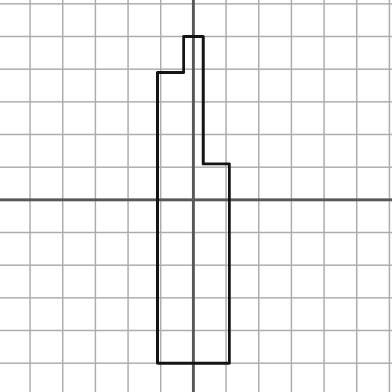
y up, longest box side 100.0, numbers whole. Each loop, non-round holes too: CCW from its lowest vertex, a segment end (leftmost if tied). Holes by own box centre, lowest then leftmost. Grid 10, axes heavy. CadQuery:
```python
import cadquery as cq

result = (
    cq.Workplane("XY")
    .moveTo(-11.0, -50.0)
    .lineTo(11.0, -50.0)
    .lineTo(11.0, 11.0)
    .lineTo(3.0, 11.0)
    .lineTo(3.0, 50.0)
    .lineTo(-3.0, 50.0)
    .lineTo(-3.0, 39.0)
    .lineTo(-11.0, 39.0)
    .close()
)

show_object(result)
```